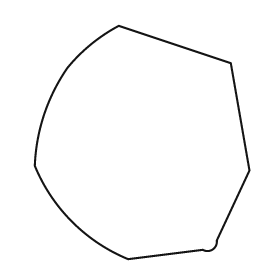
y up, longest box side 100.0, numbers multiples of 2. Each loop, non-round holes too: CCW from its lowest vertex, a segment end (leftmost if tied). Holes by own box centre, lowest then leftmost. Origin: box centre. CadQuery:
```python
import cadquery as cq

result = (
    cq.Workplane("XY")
    .moveTo(-6.0, -50.0)
    .lineTo(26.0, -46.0)
    .threePointArc((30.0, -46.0), (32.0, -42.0))
    .lineTo(46.0, -12.0)
    .lineTo(38.0, 34.0)
    .lineTo(-10.0, 50.0)
    .threePointArc((-22.0, 42.0), (-32.0, 32.0))
    .threePointArc((-42.0, 12.0), (-46.0, -10.0))
    .threePointArc((-30.0, -34.0), (-6.0, -50.0))
    .close()
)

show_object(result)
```